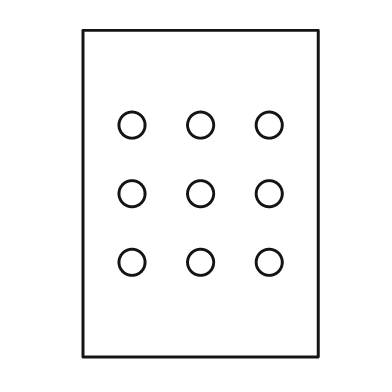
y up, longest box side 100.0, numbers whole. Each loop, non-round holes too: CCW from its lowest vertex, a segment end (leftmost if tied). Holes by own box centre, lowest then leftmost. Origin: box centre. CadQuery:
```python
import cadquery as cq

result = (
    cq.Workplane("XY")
    .moveTo(-36.0, -50.0)
    .lineTo(36.0, -50.0)
    .lineTo(36.0, 50.0)
    .lineTo(-36.0, 50.0)
    .close()
    .moveTo(-21.0, -21.0)
    .circle(4.0)
    .moveTo(0.0, -21.0)
    .circle(4.0)
    .moveTo(21.0, -21.0)
    .circle(4.0)
    .moveTo(-21.0, 0.0)
    .circle(4.0)
    .moveTo(0.0, 0.0)
    .circle(4.0)
    .moveTo(21.0, 0.0)
    .circle(4.0)
    .moveTo(-21.0, 21.0)
    .circle(4.0)
    .moveTo(0.0, 21.0)
    .circle(4.0)
    .moveTo(21.0, 21.0)
    .circle(4.0)
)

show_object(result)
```